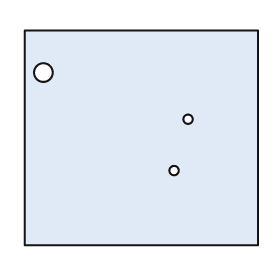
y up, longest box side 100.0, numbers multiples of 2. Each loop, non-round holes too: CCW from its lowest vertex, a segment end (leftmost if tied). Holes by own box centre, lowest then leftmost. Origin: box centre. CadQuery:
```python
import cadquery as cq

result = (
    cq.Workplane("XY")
    .moveTo(-50.0, -46.0)
    .lineTo(50.0, -46.0)
    .lineTo(50.0, 46.0)
    .lineTo(-50.0, 46.0)
    .close()
    .moveTo(14.0, -14.0)
    .circle(2.0)
    .moveTo(20.0, 8.0)
    .circle(2.0)
    .moveTo(-42.0, 28.0)
    .circle(4.0)
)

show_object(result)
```